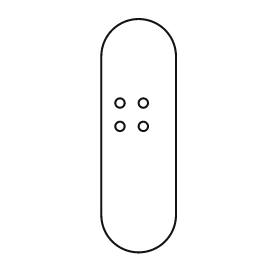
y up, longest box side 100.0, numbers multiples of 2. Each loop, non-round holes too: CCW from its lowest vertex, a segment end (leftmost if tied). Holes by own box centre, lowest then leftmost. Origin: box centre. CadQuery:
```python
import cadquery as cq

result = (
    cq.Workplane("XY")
    .moveTo(-16.0, -34.0)
    .threePointArc((0.0, -50.0), (16.0, -34.0))
    .lineTo(16.0, 34.0)
    .threePointArc((0.0, 50.0), (-16.0, 34.0))
    .close()
    .moveTo(-8.0, 4.0)
    .circle(2.0)
    .moveTo(2.0, 4.0)
    .circle(2.0)
    .moveTo(-8.0, 14.0)
    .circle(2.0)
    .moveTo(2.0, 14.0)
    .circle(2.0)
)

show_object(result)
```